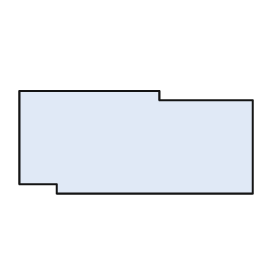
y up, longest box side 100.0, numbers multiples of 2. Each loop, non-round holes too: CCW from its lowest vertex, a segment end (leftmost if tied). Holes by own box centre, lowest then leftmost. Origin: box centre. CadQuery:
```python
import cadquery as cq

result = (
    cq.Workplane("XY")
    .moveTo(-34.0, -22.0)
    .lineTo(50.0, -22.0)
    .lineTo(50.0, 18.0)
    .lineTo(10.0, 18.0)
    .lineTo(10.0, 22.0)
    .lineTo(-50.0, 22.0)
    .lineTo(-50.0, -18.0)
    .lineTo(-34.0, -18.0)
    .close()
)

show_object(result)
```